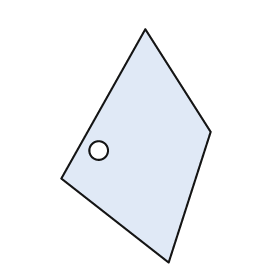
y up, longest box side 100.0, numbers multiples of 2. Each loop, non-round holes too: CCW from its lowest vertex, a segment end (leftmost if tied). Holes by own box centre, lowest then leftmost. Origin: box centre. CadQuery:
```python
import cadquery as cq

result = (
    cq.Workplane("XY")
    .moveTo(14.0, -50.0)
    .lineTo(32.0, 6.0)
    .lineTo(4.0, 50.0)
    .lineTo(-32.0, -14.0)
    .close()
    .moveTo(-16.0, -2.0)
    .circle(4.0)
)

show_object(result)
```